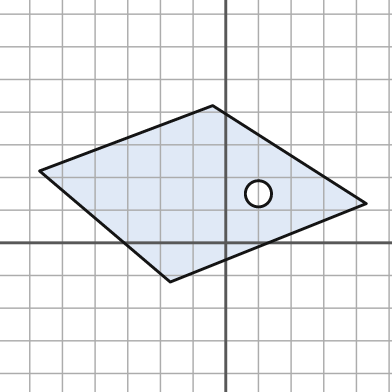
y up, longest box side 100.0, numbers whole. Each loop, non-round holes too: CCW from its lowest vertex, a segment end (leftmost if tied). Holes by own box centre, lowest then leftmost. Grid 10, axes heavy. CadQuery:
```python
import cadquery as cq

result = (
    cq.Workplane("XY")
    .moveTo(-17.0, -12.0)
    .lineTo(43.0, 12.0)
    .lineTo(-4.0, 42.0)
    .lineTo(-57.0, 22.0)
    .close()
    .moveTo(10.0, 15.0)
    .circle(4.0)
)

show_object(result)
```